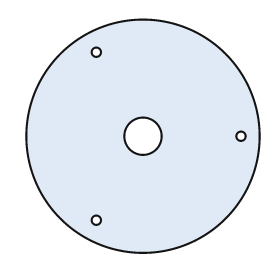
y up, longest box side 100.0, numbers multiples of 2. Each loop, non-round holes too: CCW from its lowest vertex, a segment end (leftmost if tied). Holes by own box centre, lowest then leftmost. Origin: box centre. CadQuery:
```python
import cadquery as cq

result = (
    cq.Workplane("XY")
    .moveTo(0.0, 0.0)
    .circle(50.0)
    .moveTo(-20.0, -36.0)
    .circle(2.0)
    .moveTo(0.0, 0.0)
    .circle(8.0)
    .moveTo(42.0, 0.0)
    .circle(2.0)
    .moveTo(-20.0, 36.0)
    .circle(2.0)
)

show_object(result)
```